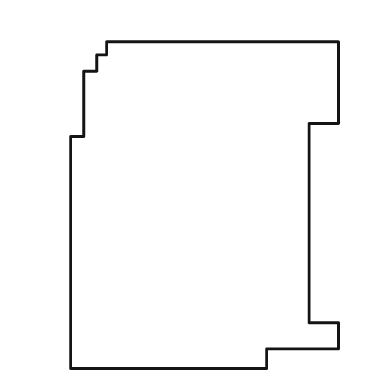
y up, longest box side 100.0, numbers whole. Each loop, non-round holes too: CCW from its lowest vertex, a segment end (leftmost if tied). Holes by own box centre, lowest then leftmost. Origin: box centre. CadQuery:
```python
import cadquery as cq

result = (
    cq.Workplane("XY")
    .moveTo(-41.0, -50.0)
    .lineTo(19.0, -50.0)
    .lineTo(19.0, -44.0)
    .lineTo(41.0, -44.0)
    .lineTo(41.0, -36.0)
    .lineTo(32.0, -36.0)
    .lineTo(32.0, 25.0)
    .lineTo(41.0, 25.0)
    .lineTo(41.0, 50.0)
    .lineTo(-30.0, 50.0)
    .lineTo(-30.0, 46.0)
    .lineTo(-33.0, 46.0)
    .lineTo(-33.0, 41.0)
    .lineTo(-37.0, 41.0)
    .lineTo(-37.0, 21.0)
    .lineTo(-41.0, 21.0)
    .close()
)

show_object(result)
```